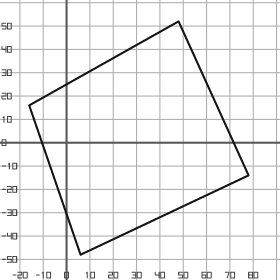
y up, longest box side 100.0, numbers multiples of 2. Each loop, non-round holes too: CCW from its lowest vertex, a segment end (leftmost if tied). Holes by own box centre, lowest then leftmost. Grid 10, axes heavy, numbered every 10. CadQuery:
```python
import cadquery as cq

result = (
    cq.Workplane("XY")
    .moveTo(6.0, -48.0)
    .lineTo(78.0, -14.0)
    .lineTo(48.0, 52.0)
    .lineTo(-16.0, 16.0)
    .close()
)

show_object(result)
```